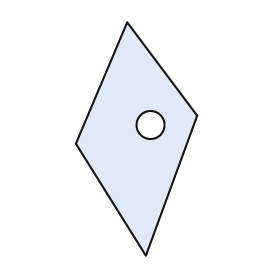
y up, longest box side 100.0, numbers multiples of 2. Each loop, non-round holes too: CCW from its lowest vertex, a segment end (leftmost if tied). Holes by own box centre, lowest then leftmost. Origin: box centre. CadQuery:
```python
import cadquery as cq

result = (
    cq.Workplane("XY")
    .moveTo(4.0, -50.0)
    .lineTo(26.0, 10.0)
    .lineTo(-4.0, 50.0)
    .lineTo(-26.0, -2.0)
    .close()
    .moveTo(6.0, 6.0)
    .circle(6.0)
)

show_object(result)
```